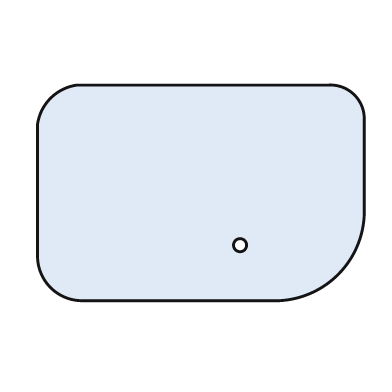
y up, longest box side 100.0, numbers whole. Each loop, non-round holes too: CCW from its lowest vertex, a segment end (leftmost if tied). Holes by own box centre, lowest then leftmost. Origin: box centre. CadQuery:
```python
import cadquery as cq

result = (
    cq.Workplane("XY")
    .moveTo(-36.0, -33.0)
    .lineTo(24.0, -33.0)
    .threePointArc((42.0, -25.0), (50.0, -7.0))
    .lineTo(50.0, 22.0)
    .threePointArc((47.0, 30.0), (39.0, 33.0))
    .lineTo(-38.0, 33.0)
    .threePointArc((-46.0, 29.0), (-50.0, 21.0))
    .lineTo(-50.0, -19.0)
    .threePointArc((-46.0, -29.0), (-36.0, -33.0))
    .close()
    .moveTo(12.0, -16.0)
    .circle(2.0)
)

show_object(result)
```